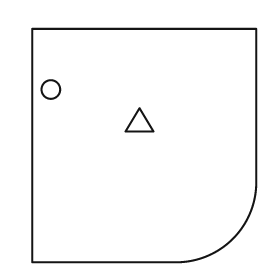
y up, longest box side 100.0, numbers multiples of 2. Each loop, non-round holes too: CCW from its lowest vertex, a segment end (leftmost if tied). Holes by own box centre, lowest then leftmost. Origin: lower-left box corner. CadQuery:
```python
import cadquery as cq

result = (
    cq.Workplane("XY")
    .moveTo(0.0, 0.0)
    .lineTo(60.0, 0.0)
    .threePointArc((86.0, 10.0), (96.0, 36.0))
    .lineTo(96.0, 100.0)
    .lineTo(0.0, 100.0)
    .close()
    .moveTo(40.0, 56.0)
    .lineTo(52.0, 56.0)
    .lineTo(46.0, 66.0)
    .close()
    .moveTo(8.0, 74.0)
    .circle(4.0)
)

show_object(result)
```